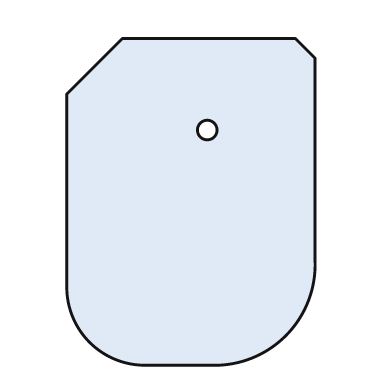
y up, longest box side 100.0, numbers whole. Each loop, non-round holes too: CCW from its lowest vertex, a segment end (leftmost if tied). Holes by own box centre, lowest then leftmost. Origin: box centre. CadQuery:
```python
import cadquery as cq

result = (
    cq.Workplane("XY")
    .moveTo(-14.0, -50.0)
    .lineTo(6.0, -50.0)
    .threePointArc((29.0, -41.0), (38.0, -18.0))
    .lineTo(38.0, 44.0)
    .lineTo(32.0, 50.0)
    .lineTo(-21.0, 50.0)
    .lineTo(-38.0, 33.0)
    .lineTo(-38.0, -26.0)
    .threePointArc((-31.0, -43.0), (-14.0, -50.0))
    .close()
    .moveTo(5.0, 22.0)
    .circle(3.0)
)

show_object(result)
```